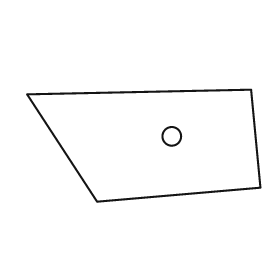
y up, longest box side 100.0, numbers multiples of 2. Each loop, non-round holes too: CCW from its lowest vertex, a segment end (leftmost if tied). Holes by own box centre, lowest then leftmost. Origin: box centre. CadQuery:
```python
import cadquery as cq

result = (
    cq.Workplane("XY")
    .moveTo(-20.0, -24.0)
    .lineTo(50.0, -18.0)
    .lineTo(46.0, 24.0)
    .lineTo(-50.0, 22.0)
    .close()
    .moveTo(12.0, 4.0)
    .circle(4.0)
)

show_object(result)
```